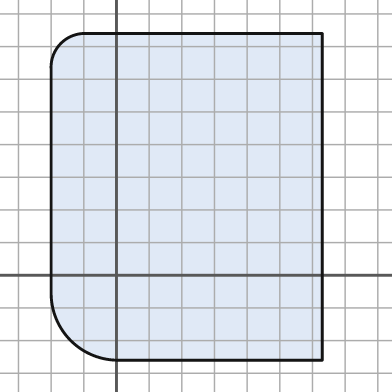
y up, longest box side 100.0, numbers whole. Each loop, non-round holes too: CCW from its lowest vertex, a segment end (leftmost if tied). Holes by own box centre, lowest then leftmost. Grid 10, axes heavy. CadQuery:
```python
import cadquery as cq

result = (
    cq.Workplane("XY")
    .moveTo(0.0, -26.0)
    .lineTo(63.0, -26.0)
    .lineTo(63.0, 74.0)
    .lineTo(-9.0, 74.0)
    .threePointArc((-17.0, 71.0), (-20.0, 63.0))
    .lineTo(-20.0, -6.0)
    .threePointArc((-14.0, -20.0), (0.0, -26.0))
    .close()
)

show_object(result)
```